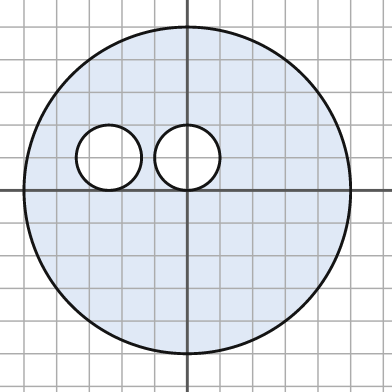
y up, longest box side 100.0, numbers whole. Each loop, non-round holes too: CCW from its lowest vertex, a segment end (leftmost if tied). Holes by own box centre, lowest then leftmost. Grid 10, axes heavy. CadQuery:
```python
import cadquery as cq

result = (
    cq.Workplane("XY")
    .moveTo(0.0, 0.0)
    .circle(50.0)
    .moveTo(-24.0, 10.0)
    .circle(10.0)
    .moveTo(0.0, 10.0)
    .circle(10.0)
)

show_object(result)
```